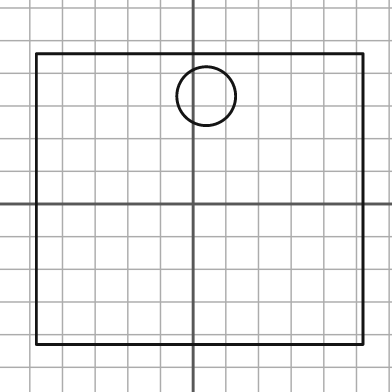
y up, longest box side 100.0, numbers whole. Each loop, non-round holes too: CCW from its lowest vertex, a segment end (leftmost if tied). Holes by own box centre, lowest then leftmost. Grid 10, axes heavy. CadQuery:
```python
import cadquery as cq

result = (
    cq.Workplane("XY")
    .moveTo(-48.0, -43.0)
    .lineTo(52.0, -43.0)
    .lineTo(52.0, 46.0)
    .lineTo(-48.0, 46.0)
    .close()
    .moveTo(4.0, 33.0)
    .circle(9.0)
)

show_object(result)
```